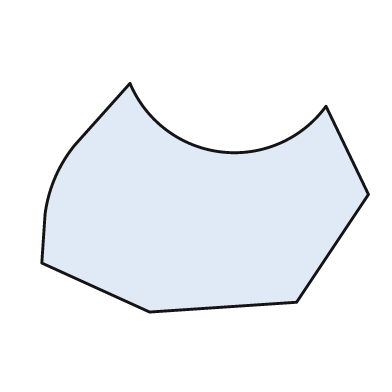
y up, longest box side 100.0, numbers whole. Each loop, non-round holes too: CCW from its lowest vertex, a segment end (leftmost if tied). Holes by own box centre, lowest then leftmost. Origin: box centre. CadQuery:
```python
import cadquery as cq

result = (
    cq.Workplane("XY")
    .moveTo(-17.0, -35.0)
    .lineTo(28.0, -32.0)
    .lineTo(50.0, 1.0)
    .lineTo(37.0, 28.0)
    .threePointArc((5.0, 14.0), (-23.0, 35.0))
    .lineTo(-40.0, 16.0)
    .threePointArc((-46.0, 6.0), (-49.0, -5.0))
    .lineTo(-50.0, -20.0)
    .close()
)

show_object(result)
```